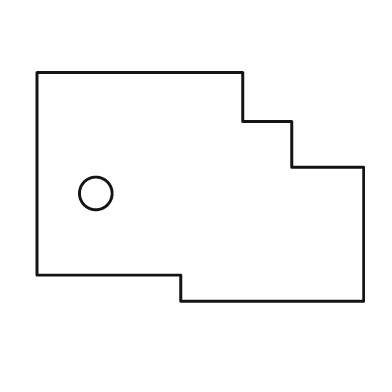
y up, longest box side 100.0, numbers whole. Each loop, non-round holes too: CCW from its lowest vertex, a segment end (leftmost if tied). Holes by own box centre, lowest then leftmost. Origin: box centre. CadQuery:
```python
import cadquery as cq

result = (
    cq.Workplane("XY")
    .moveTo(-6.0, -35.0)
    .lineTo(50.0, -35.0)
    .lineTo(50.0, 6.0)
    .lineTo(28.0, 6.0)
    .lineTo(28.0, 20.0)
    .lineTo(13.0, 20.0)
    .lineTo(13.0, 35.0)
    .lineTo(-50.0, 35.0)
    .lineTo(-50.0, -27.0)
    .lineTo(-6.0, -27.0)
    .close()
    .moveTo(-32.0, -2.0)
    .circle(5.0)
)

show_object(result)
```